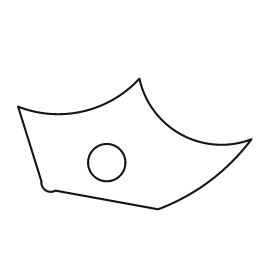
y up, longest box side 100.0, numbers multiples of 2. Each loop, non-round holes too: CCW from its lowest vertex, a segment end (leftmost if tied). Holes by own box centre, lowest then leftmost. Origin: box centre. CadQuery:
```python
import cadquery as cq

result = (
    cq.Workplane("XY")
    .moveTo(10.0, -28.0)
    .threePointArc((32.0, -16.0), (50.0, 2.0))
    .threePointArc((20.0, 4.0), (2.0, 28.0))
    .threePointArc((-22.0, 14.0), (-50.0, 16.0))
    .lineTo(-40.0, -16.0)
    .threePointArc((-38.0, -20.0), (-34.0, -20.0))
    .close()
    .moveTo(-12.0, -8.0)
    .circle(8.0)
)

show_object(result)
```